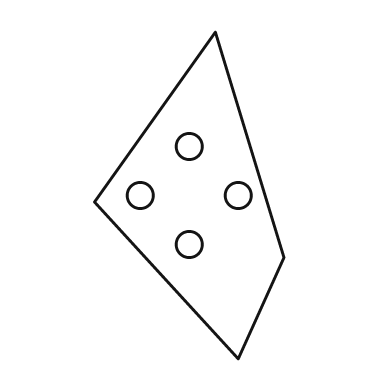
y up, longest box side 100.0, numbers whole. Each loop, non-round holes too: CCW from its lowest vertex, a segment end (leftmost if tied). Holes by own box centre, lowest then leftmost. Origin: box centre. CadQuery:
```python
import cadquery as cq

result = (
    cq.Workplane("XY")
    .moveTo(15.0, -50.0)
    .lineTo(29.0, -19.0)
    .lineTo(8.0, 50.0)
    .lineTo(-29.0, -2.0)
    .close()
    .moveTo(0.0, -15.0)
    .circle(4.0)
    .moveTo(-15.0, 0.0)
    .circle(4.0)
    .moveTo(15.0, 0.0)
    .circle(4.0)
    .moveTo(0.0, 15.0)
    .circle(4.0)
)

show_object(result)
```